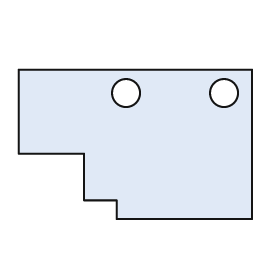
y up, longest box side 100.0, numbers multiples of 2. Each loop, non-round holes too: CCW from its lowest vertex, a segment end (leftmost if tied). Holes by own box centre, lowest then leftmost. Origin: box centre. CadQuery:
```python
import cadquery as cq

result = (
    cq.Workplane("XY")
    .moveTo(-8.0, -32.0)
    .lineTo(50.0, -32.0)
    .lineTo(50.0, 32.0)
    .lineTo(-50.0, 32.0)
    .lineTo(-50.0, -4.0)
    .lineTo(-22.0, -4.0)
    .lineTo(-22.0, -24.0)
    .lineTo(-8.0, -24.0)
    .close()
    .moveTo(-4.0, 22.0)
    .circle(6.0)
    .moveTo(38.0, 22.0)
    .circle(6.0)
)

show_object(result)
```